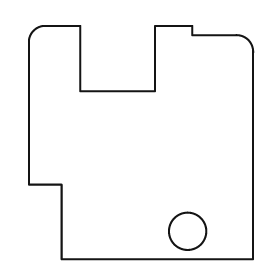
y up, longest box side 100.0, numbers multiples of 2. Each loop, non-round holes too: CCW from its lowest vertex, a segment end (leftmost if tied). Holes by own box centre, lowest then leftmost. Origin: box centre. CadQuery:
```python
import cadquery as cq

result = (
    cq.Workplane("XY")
    .moveTo(-34.0, -50.0)
    .lineTo(48.0, -50.0)
    .lineTo(48.0, 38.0)
    .threePointArc((46.0, 44.0), (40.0, 46.0))
    .lineTo(22.0, 46.0)
    .lineTo(22.0, 50.0)
    .lineTo(6.0, 50.0)
    .lineTo(6.0, 22.0)
    .lineTo(-26.0, 22.0)
    .lineTo(-26.0, 50.0)
    .lineTo(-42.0, 50.0)
    .threePointArc((-46.0, 48.0), (-48.0, 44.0))
    .lineTo(-48.0, -18.0)
    .lineTo(-34.0, -18.0)
    .close()
    .moveTo(20.0, -38.0)
    .circle(8.0)
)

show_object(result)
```